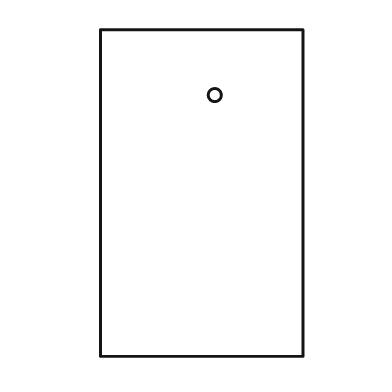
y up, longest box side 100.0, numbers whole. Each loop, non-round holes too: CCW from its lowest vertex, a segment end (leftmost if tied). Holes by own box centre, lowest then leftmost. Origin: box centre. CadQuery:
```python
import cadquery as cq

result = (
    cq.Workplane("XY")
    .moveTo(-31.0, -50.0)
    .lineTo(31.0, -50.0)
    .lineTo(31.0, 50.0)
    .lineTo(-31.0, 50.0)
    .close()
    .moveTo(4.0, 30.0)
    .circle(2.0)
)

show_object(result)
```